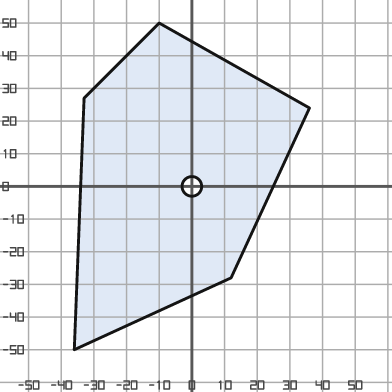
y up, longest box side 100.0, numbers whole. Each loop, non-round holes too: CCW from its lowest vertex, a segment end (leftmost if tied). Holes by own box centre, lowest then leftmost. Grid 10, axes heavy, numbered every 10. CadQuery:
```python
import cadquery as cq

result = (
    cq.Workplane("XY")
    .moveTo(-36.0, -50.0)
    .lineTo(12.0, -28.0)
    .lineTo(36.0, 24.0)
    .lineTo(-10.0, 50.0)
    .lineTo(-33.0, 27.0)
    .close()
    .moveTo(0.0, 0.0)
    .circle(3.0)
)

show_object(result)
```